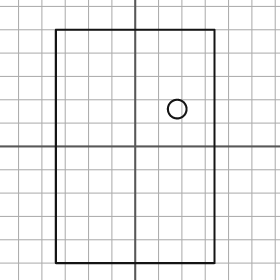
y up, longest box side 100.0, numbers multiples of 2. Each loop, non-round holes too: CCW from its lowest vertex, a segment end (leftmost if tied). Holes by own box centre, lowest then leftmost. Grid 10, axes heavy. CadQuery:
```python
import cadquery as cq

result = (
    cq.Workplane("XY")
    .moveTo(-34.0, -50.0)
    .lineTo(34.0, -50.0)
    .lineTo(34.0, 50.0)
    .lineTo(-34.0, 50.0)
    .close()
    .moveTo(18.0, 16.0)
    .circle(4.0)
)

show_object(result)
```